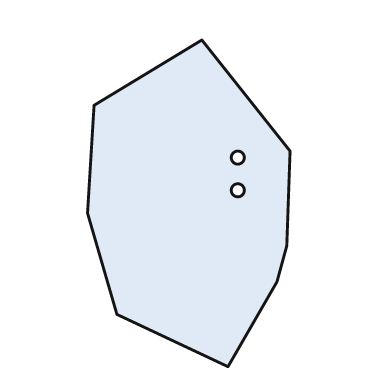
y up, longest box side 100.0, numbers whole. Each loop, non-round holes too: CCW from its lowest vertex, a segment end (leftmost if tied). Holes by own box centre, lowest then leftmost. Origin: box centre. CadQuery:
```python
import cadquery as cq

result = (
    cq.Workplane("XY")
    .moveTo(12.0, -50.0)
    .lineTo(27.0, -24.0)
    .lineTo(30.0, -13.0)
    .lineTo(31.0, 16.0)
    .lineTo(4.0, 50.0)
    .lineTo(-29.0, 30.0)
    .lineTo(-31.0, -3.0)
    .lineTo(-22.0, -34.0)
    .close()
    .moveTo(15.0, 4.0)
    .circle(2.0)
    .moveTo(15.0, 14.0)
    .circle(2.0)
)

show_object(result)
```